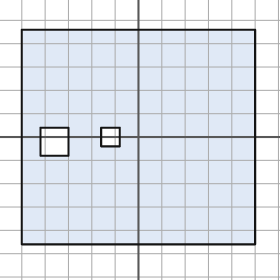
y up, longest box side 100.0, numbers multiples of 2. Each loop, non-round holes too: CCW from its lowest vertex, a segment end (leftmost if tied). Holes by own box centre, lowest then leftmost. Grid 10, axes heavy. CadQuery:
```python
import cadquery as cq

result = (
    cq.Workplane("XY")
    .moveTo(-50.0, -46.0)
    .lineTo(50.0, -46.0)
    .lineTo(50.0, 46.0)
    .lineTo(-50.0, 46.0)
    .close()
    .moveTo(-42.0, -8.0)
    .lineTo(-30.0, -8.0)
    .lineTo(-30.0, 4.0)
    .lineTo(-42.0, 4.0)
    .close()
    .moveTo(-16.0, -4.0)
    .lineTo(-8.0, -4.0)
    .lineTo(-8.0, 4.0)
    .lineTo(-16.0, 4.0)
    .close()
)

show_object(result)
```